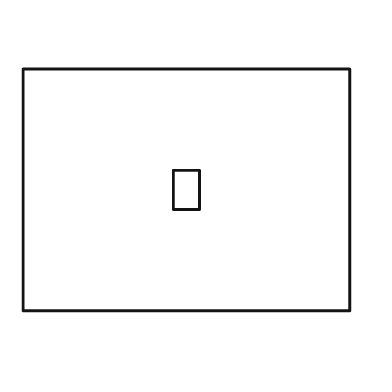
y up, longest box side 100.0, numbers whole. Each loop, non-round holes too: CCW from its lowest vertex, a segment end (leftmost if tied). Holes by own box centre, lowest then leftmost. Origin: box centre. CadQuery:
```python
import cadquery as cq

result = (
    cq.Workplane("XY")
    .moveTo(-50.0, -37.0)
    .lineTo(50.0, -37.0)
    .lineTo(50.0, 37.0)
    .lineTo(-50.0, 37.0)
    .close()
    .moveTo(-4.0, -6.0)
    .lineTo(4.0, -6.0)
    .lineTo(4.0, 6.0)
    .lineTo(-4.0, 6.0)
    .close()
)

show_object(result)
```